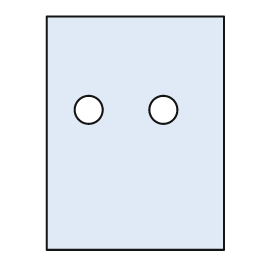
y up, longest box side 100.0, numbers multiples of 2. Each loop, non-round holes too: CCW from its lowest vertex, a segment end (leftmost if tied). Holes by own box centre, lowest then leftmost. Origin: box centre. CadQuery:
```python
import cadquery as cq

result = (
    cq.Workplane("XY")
    .moveTo(-38.0, -50.0)
    .lineTo(38.0, -50.0)
    .lineTo(38.0, 50.0)
    .lineTo(-38.0, 50.0)
    .close()
    .moveTo(-20.0, 10.0)
    .circle(6.0)
    .moveTo(12.0, 10.0)
    .circle(6.0)
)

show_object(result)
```